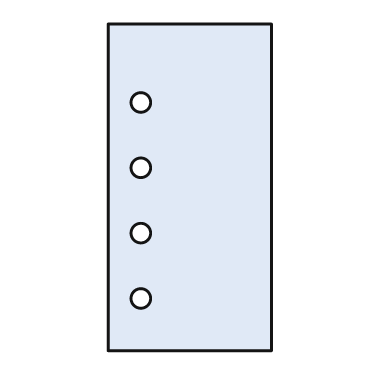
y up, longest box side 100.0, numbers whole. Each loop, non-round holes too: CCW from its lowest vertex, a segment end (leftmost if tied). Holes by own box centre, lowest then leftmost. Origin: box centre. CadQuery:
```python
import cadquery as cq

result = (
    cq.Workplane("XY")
    .moveTo(-25.0, -50.0)
    .lineTo(25.0, -50.0)
    .lineTo(25.0, 50.0)
    .lineTo(-25.0, 50.0)
    .close()
    .moveTo(-15.0, -34.0)
    .circle(3.0)
    .moveTo(-15.0, -14.0)
    .circle(3.0)
    .moveTo(-15.0, 6.0)
    .circle(3.0)
    .moveTo(-15.0, 26.0)
    .circle(3.0)
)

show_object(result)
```